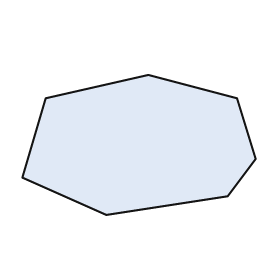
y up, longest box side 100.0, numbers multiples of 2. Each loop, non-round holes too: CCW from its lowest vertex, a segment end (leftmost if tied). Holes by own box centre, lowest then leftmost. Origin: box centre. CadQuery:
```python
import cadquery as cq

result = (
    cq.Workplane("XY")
    .moveTo(-14.0, -30.0)
    .lineTo(38.0, -22.0)
    .lineTo(50.0, -6.0)
    .lineTo(42.0, 20.0)
    .lineTo(4.0, 30.0)
    .lineTo(-40.0, 20.0)
    .lineTo(-50.0, -14.0)
    .close()
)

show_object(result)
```